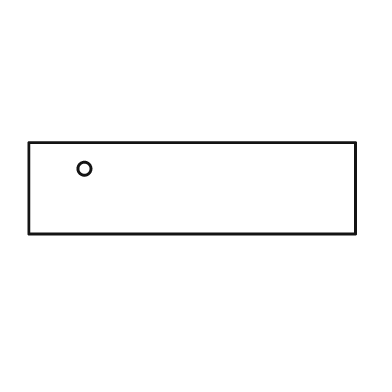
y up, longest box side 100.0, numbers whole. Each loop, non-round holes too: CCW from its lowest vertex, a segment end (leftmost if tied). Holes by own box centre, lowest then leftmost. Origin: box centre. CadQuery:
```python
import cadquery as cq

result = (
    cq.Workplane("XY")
    .moveTo(-50.0, -14.0)
    .lineTo(50.0, -14.0)
    .lineTo(50.0, 14.0)
    .lineTo(-50.0, 14.0)
    .close()
    .moveTo(-33.0, 6.0)
    .circle(2.0)
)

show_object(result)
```